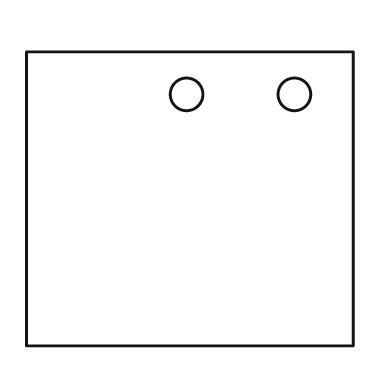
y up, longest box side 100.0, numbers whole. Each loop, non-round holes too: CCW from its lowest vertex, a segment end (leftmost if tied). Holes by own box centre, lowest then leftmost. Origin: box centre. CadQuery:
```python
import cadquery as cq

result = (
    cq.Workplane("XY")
    .moveTo(-50.0, -45.0)
    .lineTo(50.0, -45.0)
    .lineTo(50.0, 45.0)
    .lineTo(-50.0, 45.0)
    .close()
    .moveTo(-1.0, 32.0)
    .circle(5.0)
    .moveTo(32.0, 32.0)
    .circle(5.0)
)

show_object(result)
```